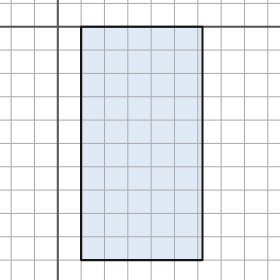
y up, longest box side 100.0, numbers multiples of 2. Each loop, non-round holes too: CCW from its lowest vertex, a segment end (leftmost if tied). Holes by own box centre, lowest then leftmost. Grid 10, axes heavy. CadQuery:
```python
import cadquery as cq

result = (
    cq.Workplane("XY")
    .moveTo(10.0, -100.0)
    .lineTo(62.0, -100.0)
    .lineTo(62.0, 0.0)
    .lineTo(10.0, 0.0)
    .close()
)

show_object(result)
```